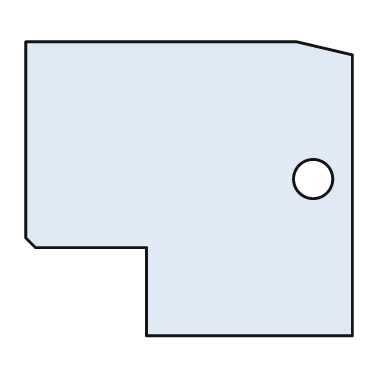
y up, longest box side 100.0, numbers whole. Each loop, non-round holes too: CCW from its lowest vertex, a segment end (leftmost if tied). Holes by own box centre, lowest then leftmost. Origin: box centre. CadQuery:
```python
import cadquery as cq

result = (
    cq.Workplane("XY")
    .moveTo(-13.0, -45.0)
    .lineTo(50.0, -45.0)
    .lineTo(50.0, 41.0)
    .lineTo(33.0, 45.0)
    .lineTo(-50.0, 45.0)
    .lineTo(-50.0, -15.0)
    .lineTo(-47.0, -18.0)
    .lineTo(-13.0, -18.0)
    .close()
    .moveTo(38.0, 3.0)
    .circle(6.0)
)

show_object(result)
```